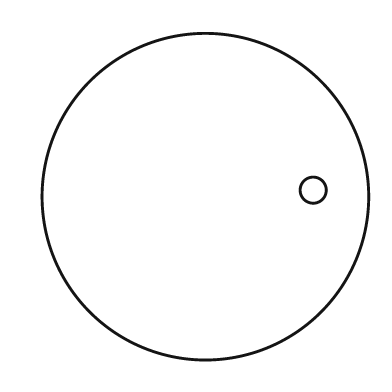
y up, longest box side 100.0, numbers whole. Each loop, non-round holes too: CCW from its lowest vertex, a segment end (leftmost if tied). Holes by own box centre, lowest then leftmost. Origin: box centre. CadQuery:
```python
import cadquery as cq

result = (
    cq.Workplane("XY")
    .moveTo(0.0, 0.0)
    .circle(50.0)
    .moveTo(33.0, 2.0)
    .circle(4.0)
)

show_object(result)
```